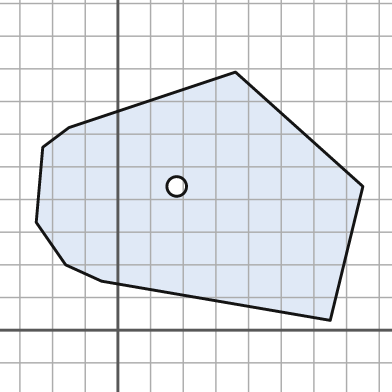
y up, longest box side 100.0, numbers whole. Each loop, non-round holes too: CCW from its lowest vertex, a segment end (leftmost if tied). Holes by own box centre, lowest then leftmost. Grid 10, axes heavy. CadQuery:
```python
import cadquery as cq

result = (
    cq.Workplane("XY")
    .moveTo(65.0, 3.0)
    .lineTo(75.0, 44.0)
    .lineTo(36.0, 79.0)
    .lineTo(-15.0, 62.0)
    .lineTo(-23.0, 56.0)
    .lineTo(-25.0, 33.0)
    .lineTo(-16.0, 20.0)
    .lineTo(-5.0, 15.0)
    .close()
    .moveTo(18.0, 44.0)
    .circle(3.0)
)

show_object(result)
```